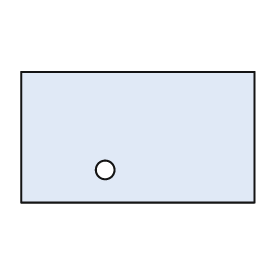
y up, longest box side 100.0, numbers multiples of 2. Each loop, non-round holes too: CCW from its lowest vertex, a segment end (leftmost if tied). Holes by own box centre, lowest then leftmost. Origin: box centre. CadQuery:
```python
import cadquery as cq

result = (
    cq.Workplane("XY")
    .moveTo(-50.0, -28.0)
    .lineTo(50.0, -28.0)
    .lineTo(50.0, 28.0)
    .lineTo(-50.0, 28.0)
    .close()
    .moveTo(-14.0, -14.0)
    .circle(4.0)
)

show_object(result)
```